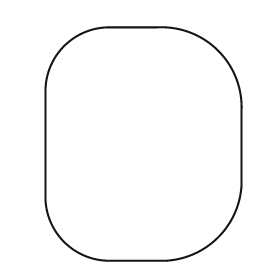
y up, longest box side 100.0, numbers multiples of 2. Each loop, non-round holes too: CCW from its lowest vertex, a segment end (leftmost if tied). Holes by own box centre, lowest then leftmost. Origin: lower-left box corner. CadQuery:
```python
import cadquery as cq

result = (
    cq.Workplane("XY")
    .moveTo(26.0, 0.0)
    .lineTo(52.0, 0.0)
    .threePointArc((74.0, 10.0), (84.0, 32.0))
    .lineTo(84.0, 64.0)
    .threePointArc((74.0, 90.0), (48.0, 100.0))
    .lineTo(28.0, 100.0)
    .threePointArc((8.0, 92.0), (0.0, 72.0))
    .lineTo(0.0, 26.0)
    .threePointArc((8.0, 8.0), (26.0, 0.0))
    .close()
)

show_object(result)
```